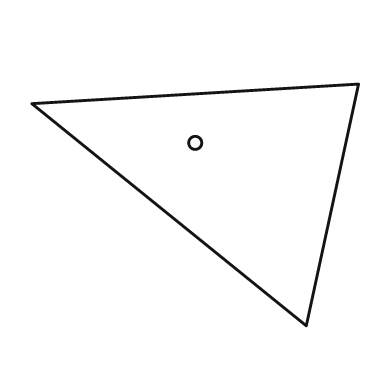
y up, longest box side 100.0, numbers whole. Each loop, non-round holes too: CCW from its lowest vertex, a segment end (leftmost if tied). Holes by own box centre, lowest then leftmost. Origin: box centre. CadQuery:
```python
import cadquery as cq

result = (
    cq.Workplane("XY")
    .moveTo(34.0, -37.0)
    .lineTo(50.0, 37.0)
    .lineTo(-50.0, 31.0)
    .close()
    .moveTo(0.0, 19.0)
    .circle(2.0)
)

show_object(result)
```